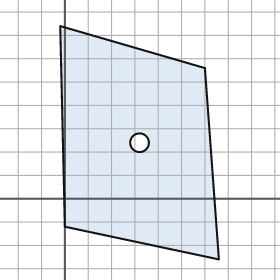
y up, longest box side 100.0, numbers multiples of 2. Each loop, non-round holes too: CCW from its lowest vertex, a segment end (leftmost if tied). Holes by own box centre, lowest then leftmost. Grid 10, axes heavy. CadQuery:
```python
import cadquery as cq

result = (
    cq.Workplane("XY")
    .moveTo(66.0, -26.0)
    .lineTo(60.0, 56.0)
    .lineTo(-2.0, 74.0)
    .lineTo(0.0, -12.0)
    .close()
    .moveTo(32.0, 24.0)
    .circle(4.0)
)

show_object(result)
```